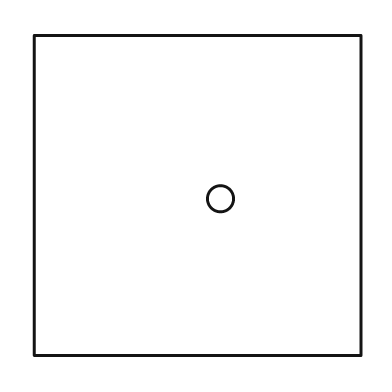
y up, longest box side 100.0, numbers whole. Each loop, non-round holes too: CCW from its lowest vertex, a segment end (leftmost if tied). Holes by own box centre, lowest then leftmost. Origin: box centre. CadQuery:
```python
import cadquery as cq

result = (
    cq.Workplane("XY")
    .moveTo(-50.0, -49.0)
    .lineTo(50.0, -49.0)
    .lineTo(50.0, 49.0)
    .lineTo(-50.0, 49.0)
    .close()
    .moveTo(7.0, -1.0)
    .circle(4.0)
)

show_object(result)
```